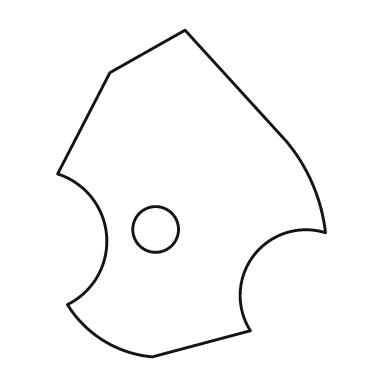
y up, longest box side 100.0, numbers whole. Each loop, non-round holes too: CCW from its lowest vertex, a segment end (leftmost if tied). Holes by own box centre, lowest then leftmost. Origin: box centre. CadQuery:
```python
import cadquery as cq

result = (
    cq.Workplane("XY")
    .moveTo(-12.0, -50.0)
    .lineTo(18.0, -42.0)
    .threePointArc((19.0, -19.0), (41.0, -12.0))
    .threePointArc((37.0, 3.0), (29.0, 16.0))
    .lineTo(-2.0, 50.0)
    .lineTo(-25.0, 37.0)
    .lineTo(-41.0, 6.0)
    .threePointArc((-26.0, -13.0), (-38.0, -34.0))
    .threePointArc((-27.0, -45.0), (-12.0, -50.0))
    .close()
    .moveTo(-11.0, -11.0)
    .circle(7.0)
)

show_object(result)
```